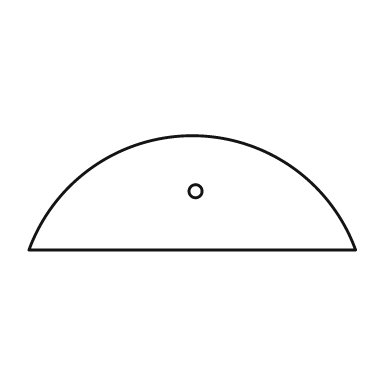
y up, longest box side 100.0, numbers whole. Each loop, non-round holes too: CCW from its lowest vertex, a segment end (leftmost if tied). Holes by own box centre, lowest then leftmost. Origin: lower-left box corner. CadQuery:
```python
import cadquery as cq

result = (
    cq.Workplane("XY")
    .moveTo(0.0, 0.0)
    .lineTo(100.0, 0.0)
    .threePointArc((50.0, 35.0), (0.0, 0.0))
    .close()
    .moveTo(51.0, 18.0)
    .circle(2.0)
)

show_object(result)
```